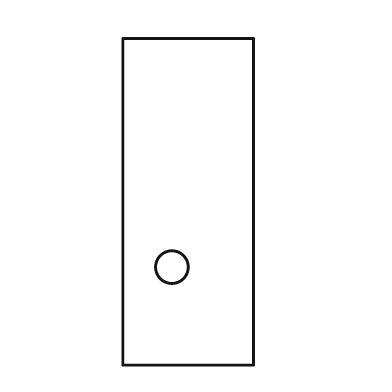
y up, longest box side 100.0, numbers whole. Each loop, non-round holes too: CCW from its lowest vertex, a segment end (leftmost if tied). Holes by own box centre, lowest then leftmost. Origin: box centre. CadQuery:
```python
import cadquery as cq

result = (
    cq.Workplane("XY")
    .moveTo(-20.0, -50.0)
    .lineTo(20.0, -50.0)
    .lineTo(20.0, 50.0)
    .lineTo(-20.0, 50.0)
    .close()
    .moveTo(-5.0, -20.0)
    .circle(5.0)
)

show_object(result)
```